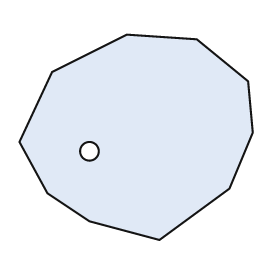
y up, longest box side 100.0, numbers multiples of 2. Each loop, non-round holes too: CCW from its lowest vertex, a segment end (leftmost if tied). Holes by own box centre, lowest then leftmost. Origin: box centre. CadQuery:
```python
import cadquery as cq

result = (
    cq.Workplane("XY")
    .moveTo(10.0, -44.0)
    .lineTo(40.0, -22.0)
    .lineTo(50.0, 2.0)
    .lineTo(48.0, 24.0)
    .lineTo(26.0, 42.0)
    .lineTo(-4.0, 44.0)
    .lineTo(-36.0, 28.0)
    .lineTo(-50.0, -2.0)
    .lineTo(-38.0, -24.0)
    .lineTo(-20.0, -36.0)
    .close()
    .moveTo(-20.0, -6.0)
    .circle(4.0)
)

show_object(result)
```